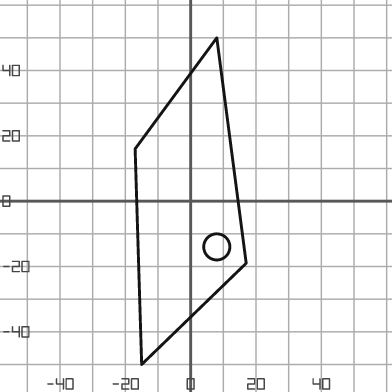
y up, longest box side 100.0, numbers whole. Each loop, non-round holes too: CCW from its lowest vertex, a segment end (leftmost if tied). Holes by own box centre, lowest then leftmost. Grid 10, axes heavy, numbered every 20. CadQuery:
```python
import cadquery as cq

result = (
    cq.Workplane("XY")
    .moveTo(-15.0, -50.0)
    .lineTo(17.0, -19.0)
    .lineTo(8.0, 50.0)
    .lineTo(-17.0, 16.0)
    .close()
    .moveTo(8.0, -14.0)
    .circle(4.0)
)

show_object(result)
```